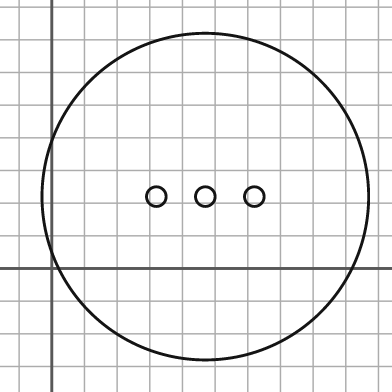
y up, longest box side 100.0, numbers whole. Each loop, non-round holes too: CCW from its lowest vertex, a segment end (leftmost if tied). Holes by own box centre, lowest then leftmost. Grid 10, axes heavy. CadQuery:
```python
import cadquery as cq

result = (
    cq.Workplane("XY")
    .moveTo(47.0, 22.0)
    .circle(50.0)
    .moveTo(32.0, 22.0)
    .circle(3.0)
    .moveTo(47.0, 22.0)
    .circle(3.0)
    .moveTo(62.0, 22.0)
    .circle(3.0)
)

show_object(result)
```